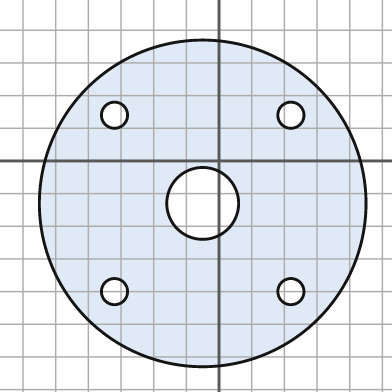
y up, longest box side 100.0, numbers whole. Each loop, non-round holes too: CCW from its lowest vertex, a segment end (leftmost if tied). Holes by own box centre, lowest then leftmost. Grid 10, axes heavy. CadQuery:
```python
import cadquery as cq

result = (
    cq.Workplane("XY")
    .moveTo(-5.0, -13.0)
    .circle(50.0)
    .moveTo(-32.0, -40.0)
    .circle(4.0)
    .moveTo(22.0, -40.0)
    .circle(4.0)
    .moveTo(-5.0, -13.0)
    .circle(11.0)
    .moveTo(-32.0, 14.0)
    .circle(4.0)
    .moveTo(22.0, 14.0)
    .circle(4.0)
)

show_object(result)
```